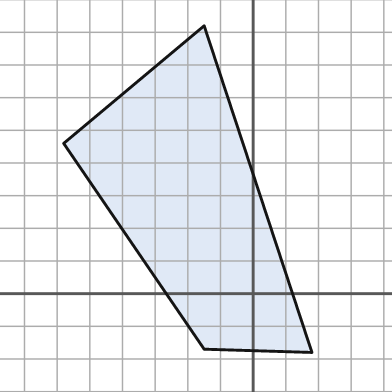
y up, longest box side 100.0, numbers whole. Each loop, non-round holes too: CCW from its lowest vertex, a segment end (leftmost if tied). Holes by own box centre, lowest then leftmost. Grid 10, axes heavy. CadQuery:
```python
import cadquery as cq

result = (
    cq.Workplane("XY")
    .moveTo(18.0, -18.0)
    .lineTo(-15.0, 82.0)
    .lineTo(-58.0, 46.0)
    .lineTo(-15.0, -17.0)
    .close()
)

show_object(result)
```